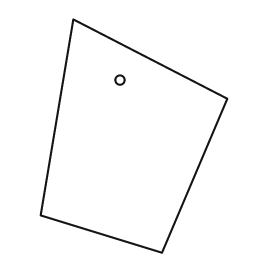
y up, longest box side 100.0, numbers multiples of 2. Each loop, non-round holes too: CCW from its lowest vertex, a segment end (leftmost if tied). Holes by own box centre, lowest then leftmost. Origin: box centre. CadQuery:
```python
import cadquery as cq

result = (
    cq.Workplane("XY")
    .moveTo(12.0, -50.0)
    .lineTo(40.0, 16.0)
    .lineTo(-26.0, 50.0)
    .lineTo(-40.0, -34.0)
    .close()
    .moveTo(-6.0, 24.0)
    .circle(2.0)
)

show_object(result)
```